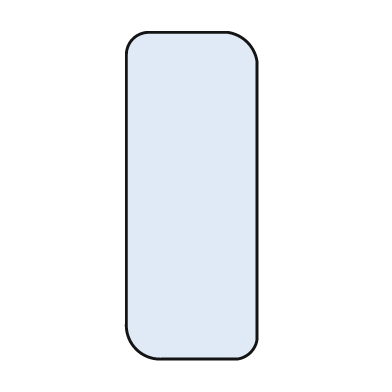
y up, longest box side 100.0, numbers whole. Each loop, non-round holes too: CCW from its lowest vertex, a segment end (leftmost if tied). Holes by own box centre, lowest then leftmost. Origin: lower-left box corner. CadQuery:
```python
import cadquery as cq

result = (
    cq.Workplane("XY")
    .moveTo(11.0, 0.0)
    .lineTo(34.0, 0.0)
    .threePointArc((38.0, 2.0), (40.0, 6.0))
    .lineTo(40.0, 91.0)
    .threePointArc((37.0, 97.0), (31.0, 100.0))
    .lineTo(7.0, 100.0)
    .threePointArc((2.0, 98.0), (0.0, 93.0))
    .lineTo(0.0, 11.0)
    .threePointArc((3.0, 3.0), (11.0, 0.0))
    .close()
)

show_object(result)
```